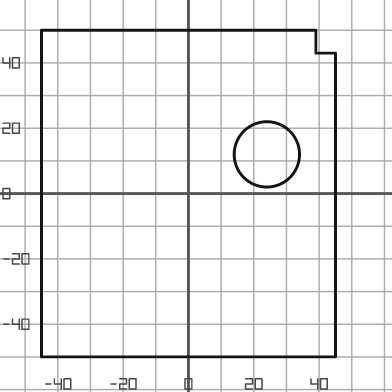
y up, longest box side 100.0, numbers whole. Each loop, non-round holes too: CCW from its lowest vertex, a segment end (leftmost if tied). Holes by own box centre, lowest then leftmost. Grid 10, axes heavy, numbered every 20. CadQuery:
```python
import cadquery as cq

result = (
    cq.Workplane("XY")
    .moveTo(-45.0, -50.0)
    .lineTo(45.0, -50.0)
    .lineTo(45.0, 43.0)
    .lineTo(39.0, 43.0)
    .lineTo(39.0, 50.0)
    .lineTo(-45.0, 50.0)
    .close()
    .moveTo(24.0, 12.0)
    .circle(10.0)
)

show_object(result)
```